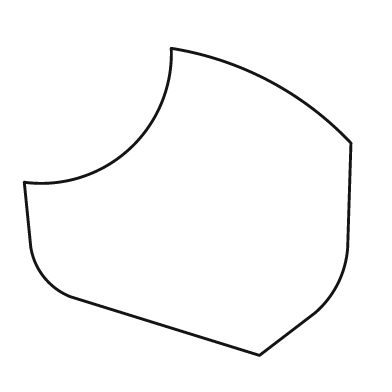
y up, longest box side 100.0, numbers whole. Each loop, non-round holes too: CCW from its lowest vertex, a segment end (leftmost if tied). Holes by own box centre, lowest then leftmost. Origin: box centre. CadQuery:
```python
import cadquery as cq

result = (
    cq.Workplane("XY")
    .moveTo(22.0, -47.0)
    .lineTo(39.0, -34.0)
    .threePointArc((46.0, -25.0), (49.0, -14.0))
    .lineTo(50.0, 18.0)
    .threePointArc((25.0, 37.0), (-5.0, 47.0))
    .threePointArc((-18.0, 16.0), (-50.0, 6.0))
    .lineTo(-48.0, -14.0)
    .threePointArc((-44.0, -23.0), (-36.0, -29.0))
    .close()
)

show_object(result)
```